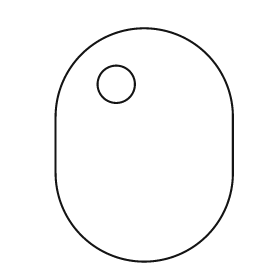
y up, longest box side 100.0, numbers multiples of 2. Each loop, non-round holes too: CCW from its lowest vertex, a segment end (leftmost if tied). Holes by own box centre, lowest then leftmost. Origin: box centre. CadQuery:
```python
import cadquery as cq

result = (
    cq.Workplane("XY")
    .moveTo(-38.0, -12.0)
    .threePointArc((0.0, -50.0), (38.0, -12.0))
    .lineTo(38.0, 12.0)
    .threePointArc((0.0, 50.0), (-38.0, 12.0))
    .close()
    .moveTo(-12.0, 26.0)
    .circle(8.0)
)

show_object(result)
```